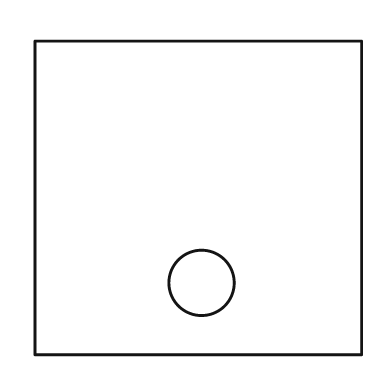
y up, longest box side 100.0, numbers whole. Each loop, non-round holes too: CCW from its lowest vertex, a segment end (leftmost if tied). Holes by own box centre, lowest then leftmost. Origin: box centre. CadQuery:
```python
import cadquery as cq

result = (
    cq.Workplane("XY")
    .moveTo(-50.0, -48.0)
    .lineTo(50.0, -48.0)
    .lineTo(50.0, 48.0)
    .lineTo(-50.0, 48.0)
    .close()
    .moveTo(1.0, -26.0)
    .circle(10.0)
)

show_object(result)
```